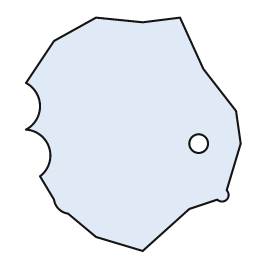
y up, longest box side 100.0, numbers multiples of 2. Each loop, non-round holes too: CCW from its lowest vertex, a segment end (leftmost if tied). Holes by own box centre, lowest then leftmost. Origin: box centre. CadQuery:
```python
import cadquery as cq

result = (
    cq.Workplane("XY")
    .moveTo(4.0, -50.0)
    .lineTo(24.0, -32.0)
    .lineTo(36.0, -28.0)
    .threePointArc((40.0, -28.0), (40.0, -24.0))
    .lineTo(46.0, -4.0)
    .lineTo(44.0, 10.0)
    .lineTo(30.0, 28.0)
    .lineTo(20.0, 50.0)
    .lineTo(4.0, 48.0)
    .lineTo(-16.0, 50.0)
    .lineTo(-34.0, 40.0)
    .lineTo(-46.0, 22.0)
    .threePointArc((-40.0, 12.0), (-46.0, 2.0))
    .threePointArc((-36.0, -6.0), (-40.0, -18.0))
    .lineTo(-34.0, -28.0)
    .threePointArc((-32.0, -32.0), (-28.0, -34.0))
    .lineTo(-16.0, -44.0)
    .close()
    .moveTo(28.0, -4.0)
    .circle(4.0)
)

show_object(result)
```